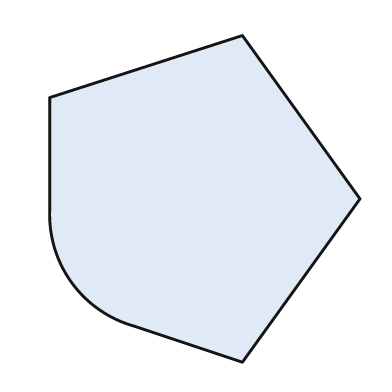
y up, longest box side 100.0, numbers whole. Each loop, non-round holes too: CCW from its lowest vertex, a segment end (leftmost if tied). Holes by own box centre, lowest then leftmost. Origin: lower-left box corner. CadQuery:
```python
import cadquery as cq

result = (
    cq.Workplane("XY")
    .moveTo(59.0, 0.0)
    .lineTo(95.0, 50.0)
    .lineTo(59.0, 100.0)
    .lineTo(0.0, 81.0)
    .lineTo(0.0, 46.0)
    .threePointArc((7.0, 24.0), (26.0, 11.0))
    .close()
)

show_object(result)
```